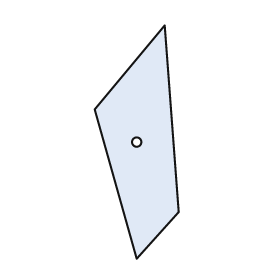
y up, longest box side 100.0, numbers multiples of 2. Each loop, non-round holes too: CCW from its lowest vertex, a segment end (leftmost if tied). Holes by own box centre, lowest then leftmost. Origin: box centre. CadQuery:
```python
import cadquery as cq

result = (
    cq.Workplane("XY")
    .moveTo(0.0, -50.0)
    .lineTo(18.0, -30.0)
    .lineTo(12.0, 50.0)
    .lineTo(-18.0, 14.0)
    .close()
    .moveTo(0.0, 0.0)
    .circle(2.0)
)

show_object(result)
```